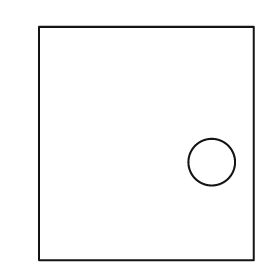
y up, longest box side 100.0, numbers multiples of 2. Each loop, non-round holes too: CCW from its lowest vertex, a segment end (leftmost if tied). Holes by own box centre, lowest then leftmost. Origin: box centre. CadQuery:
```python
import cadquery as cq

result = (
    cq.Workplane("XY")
    .moveTo(-46.0, -50.0)
    .lineTo(46.0, -50.0)
    .lineTo(46.0, 50.0)
    .lineTo(-46.0, 50.0)
    .close()
    .moveTo(28.0, -8.0)
    .circle(10.0)
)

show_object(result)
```